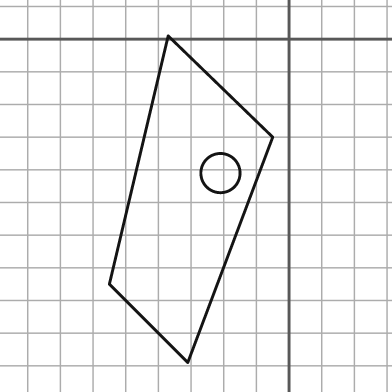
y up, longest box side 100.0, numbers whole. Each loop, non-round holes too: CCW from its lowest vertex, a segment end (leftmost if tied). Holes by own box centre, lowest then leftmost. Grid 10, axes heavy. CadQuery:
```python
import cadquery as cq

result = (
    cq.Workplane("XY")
    .moveTo(-31.0, -99.0)
    .lineTo(-5.0, -30.0)
    .lineTo(-37.0, 1.0)
    .lineTo(-55.0, -75.0)
    .close()
    .moveTo(-21.0, -41.0)
    .circle(6.0)
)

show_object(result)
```